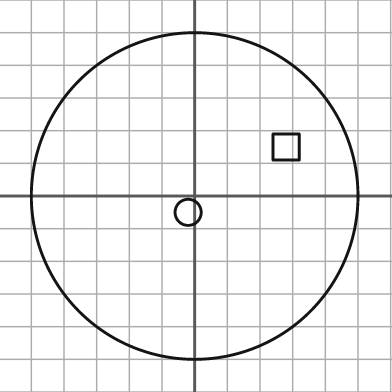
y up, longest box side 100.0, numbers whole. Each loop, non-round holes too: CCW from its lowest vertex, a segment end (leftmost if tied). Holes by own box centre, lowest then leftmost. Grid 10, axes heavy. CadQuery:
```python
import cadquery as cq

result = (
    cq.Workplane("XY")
    .moveTo(0.0, 0.0)
    .circle(50.0)
    .moveTo(-2.0, -5.0)
    .circle(4.0)
    .moveTo(24.0, 11.0)
    .lineTo(32.0, 11.0)
    .lineTo(32.0, 19.0)
    .lineTo(24.0, 19.0)
    .close()
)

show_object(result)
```